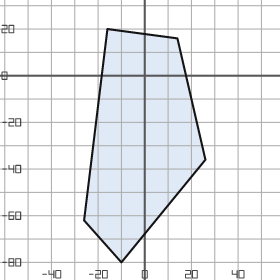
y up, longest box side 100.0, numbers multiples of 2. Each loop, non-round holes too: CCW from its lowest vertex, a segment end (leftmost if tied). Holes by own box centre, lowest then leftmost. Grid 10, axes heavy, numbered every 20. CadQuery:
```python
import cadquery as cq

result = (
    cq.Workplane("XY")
    .moveTo(-10.0, -80.0)
    .lineTo(26.0, -36.0)
    .lineTo(14.0, 16.0)
    .lineTo(-16.0, 20.0)
    .lineTo(-26.0, -62.0)
    .close()
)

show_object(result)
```